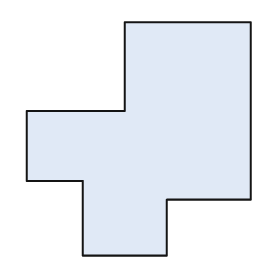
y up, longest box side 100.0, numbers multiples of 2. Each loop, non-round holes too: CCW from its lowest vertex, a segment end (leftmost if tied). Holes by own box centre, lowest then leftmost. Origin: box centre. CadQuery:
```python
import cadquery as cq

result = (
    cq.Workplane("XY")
    .moveTo(-24.0, -50.0)
    .lineTo(12.0, -50.0)
    .lineTo(12.0, -26.0)
    .lineTo(48.0, -26.0)
    .lineTo(48.0, 50.0)
    .lineTo(-6.0, 50.0)
    .lineTo(-6.0, 12.0)
    .lineTo(-48.0, 12.0)
    .lineTo(-48.0, -18.0)
    .lineTo(-24.0, -18.0)
    .close()
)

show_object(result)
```